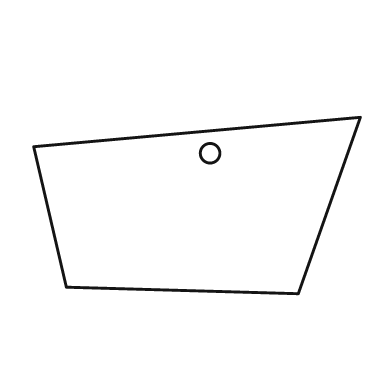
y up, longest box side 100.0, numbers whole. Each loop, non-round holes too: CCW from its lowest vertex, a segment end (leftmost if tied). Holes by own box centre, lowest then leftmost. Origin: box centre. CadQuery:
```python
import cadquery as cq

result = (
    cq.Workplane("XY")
    .moveTo(31.0, -27.0)
    .lineTo(50.0, 27.0)
    .lineTo(-50.0, 18.0)
    .lineTo(-40.0, -25.0)
    .close()
    .moveTo(4.0, 16.0)
    .circle(3.0)
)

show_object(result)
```